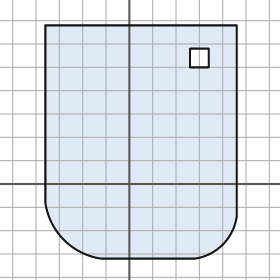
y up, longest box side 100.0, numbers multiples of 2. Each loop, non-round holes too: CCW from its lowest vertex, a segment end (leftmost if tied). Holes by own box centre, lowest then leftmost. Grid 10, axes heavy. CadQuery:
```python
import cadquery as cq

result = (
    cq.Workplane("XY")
    .moveTo(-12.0, -32.0)
    .lineTo(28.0, -32.0)
    .threePointArc((40.0, -26.0), (46.0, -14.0))
    .lineTo(46.0, 68.0)
    .lineTo(-36.0, 68.0)
    .lineTo(-36.0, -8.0)
    .threePointArc((-28.0, -24.0), (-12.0, -32.0))
    .close()
    .moveTo(26.0, 50.0)
    .lineTo(34.0, 50.0)
    .lineTo(34.0, 58.0)
    .lineTo(26.0, 58.0)
    .close()
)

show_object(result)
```